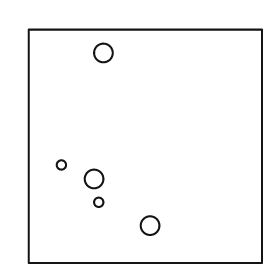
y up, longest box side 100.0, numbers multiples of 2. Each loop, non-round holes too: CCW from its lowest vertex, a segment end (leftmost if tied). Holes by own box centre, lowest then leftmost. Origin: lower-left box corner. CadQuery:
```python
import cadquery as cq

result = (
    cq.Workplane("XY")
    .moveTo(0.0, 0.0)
    .lineTo(100.0, 0.0)
    .lineTo(100.0, 100.0)
    .lineTo(0.0, 100.0)
    .close()
    .moveTo(52.0, 16.0)
    .circle(4.0)
    .moveTo(30.0, 26.0)
    .circle(2.0)
    .moveTo(28.0, 36.0)
    .circle(4.0)
    .moveTo(14.0, 42.0)
    .circle(2.0)
    .moveTo(32.0, 90.0)
    .circle(4.0)
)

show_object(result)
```